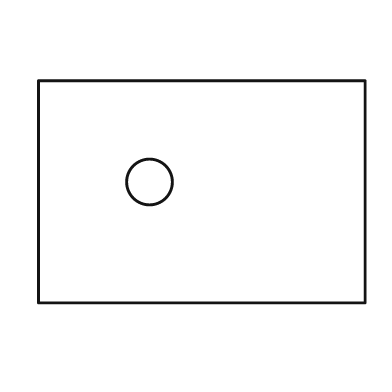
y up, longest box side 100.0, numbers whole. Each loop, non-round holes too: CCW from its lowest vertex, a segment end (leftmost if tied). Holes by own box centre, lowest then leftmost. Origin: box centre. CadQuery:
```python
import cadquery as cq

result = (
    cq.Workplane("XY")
    .moveTo(-50.0, -34.0)
    .lineTo(50.0, -34.0)
    .lineTo(50.0, 34.0)
    .lineTo(-50.0, 34.0)
    .close()
    .moveTo(-16.0, 3.0)
    .circle(7.0)
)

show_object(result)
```